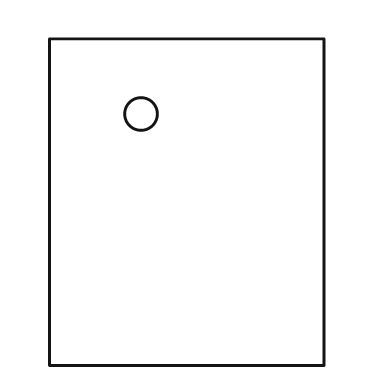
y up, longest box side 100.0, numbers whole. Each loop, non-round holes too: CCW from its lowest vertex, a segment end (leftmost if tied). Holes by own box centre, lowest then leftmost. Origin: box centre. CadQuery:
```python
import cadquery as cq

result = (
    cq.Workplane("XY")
    .moveTo(-42.0, -50.0)
    .lineTo(42.0, -50.0)
    .lineTo(42.0, 50.0)
    .lineTo(-42.0, 50.0)
    .close()
    .moveTo(-14.0, 27.0)
    .circle(5.0)
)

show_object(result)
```